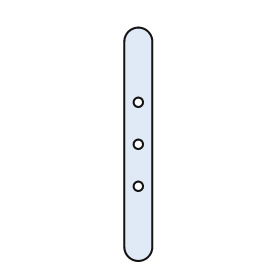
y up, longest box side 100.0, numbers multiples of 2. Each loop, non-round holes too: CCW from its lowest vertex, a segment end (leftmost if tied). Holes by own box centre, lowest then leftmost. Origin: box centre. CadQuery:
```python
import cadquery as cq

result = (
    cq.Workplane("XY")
    .moveTo(-6.0, -44.0)
    .threePointArc((0.0, -50.0), (6.0, -44.0))
    .lineTo(6.0, 44.0)
    .threePointArc((0.0, 50.0), (-6.0, 44.0))
    .close()
    .moveTo(0.0, -18.0)
    .circle(2.0)
    .moveTo(0.0, 0.0)
    .circle(2.0)
    .moveTo(0.0, 18.0)
    .circle(2.0)
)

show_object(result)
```